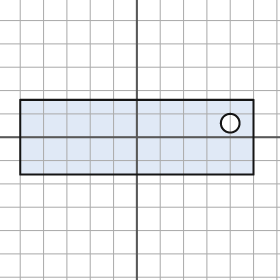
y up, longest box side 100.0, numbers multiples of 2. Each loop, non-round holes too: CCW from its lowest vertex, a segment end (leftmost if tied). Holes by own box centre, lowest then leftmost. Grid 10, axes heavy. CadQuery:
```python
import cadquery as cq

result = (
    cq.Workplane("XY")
    .moveTo(-50.0, -16.0)
    .lineTo(50.0, -16.0)
    .lineTo(50.0, 16.0)
    .lineTo(-50.0, 16.0)
    .close()
    .moveTo(40.0, 6.0)
    .circle(4.0)
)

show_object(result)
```